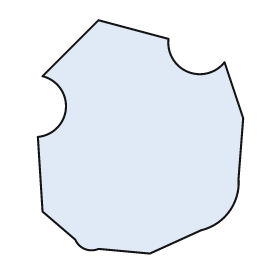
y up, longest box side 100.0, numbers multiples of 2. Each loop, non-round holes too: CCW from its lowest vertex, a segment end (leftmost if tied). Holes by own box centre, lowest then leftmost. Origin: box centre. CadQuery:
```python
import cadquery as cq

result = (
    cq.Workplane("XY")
    .moveTo(4.0, -50.0)
    .lineTo(26.0, -40.0)
    .threePointArc((38.0, -32.0), (42.0, -18.0))
    .lineTo(44.0, 8.0)
    .lineTo(36.0, 32.0)
    .threePointArc((20.0, 28.0), (12.0, 42.0))
    .lineTo(-18.0, 50.0)
    .lineTo(-42.0, 26.0)
    .threePointArc((-32.0, 12.0), (-44.0, 0.0))
    .lineTo(-42.0, -32.0)
    .lineTo(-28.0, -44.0)
    .threePointArc((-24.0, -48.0), (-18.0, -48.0))
    .close()
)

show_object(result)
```